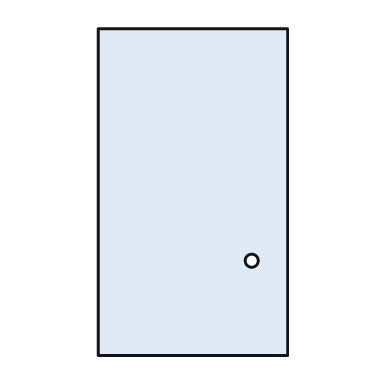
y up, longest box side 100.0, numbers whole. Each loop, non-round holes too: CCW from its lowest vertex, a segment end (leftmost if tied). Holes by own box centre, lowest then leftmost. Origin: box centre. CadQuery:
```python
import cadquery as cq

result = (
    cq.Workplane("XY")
    .moveTo(-29.0, -50.0)
    .lineTo(29.0, -50.0)
    .lineTo(29.0, 50.0)
    .lineTo(-29.0, 50.0)
    .close()
    .moveTo(18.0, -21.0)
    .circle(2.0)
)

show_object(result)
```